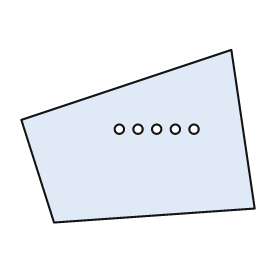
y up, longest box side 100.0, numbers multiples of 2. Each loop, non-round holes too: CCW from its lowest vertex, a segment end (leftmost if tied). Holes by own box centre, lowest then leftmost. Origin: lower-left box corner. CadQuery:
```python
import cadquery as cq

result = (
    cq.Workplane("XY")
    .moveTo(14.0, 0.0)
    .lineTo(100.0, 6.0)
    .lineTo(90.0, 74.0)
    .lineTo(0.0, 44.0)
    .close()
    .moveTo(42.0, 40.0)
    .circle(2.0)
    .moveTo(50.0, 40.0)
    .circle(2.0)
    .moveTo(58.0, 40.0)
    .circle(2.0)
    .moveTo(66.0, 40.0)
    .circle(2.0)
    .moveTo(74.0, 40.0)
    .circle(2.0)
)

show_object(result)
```